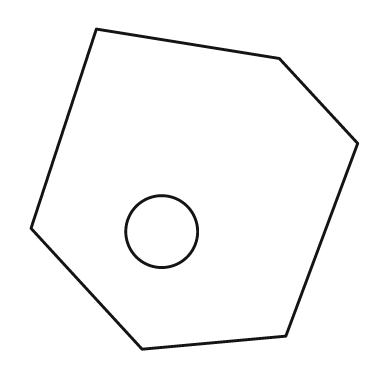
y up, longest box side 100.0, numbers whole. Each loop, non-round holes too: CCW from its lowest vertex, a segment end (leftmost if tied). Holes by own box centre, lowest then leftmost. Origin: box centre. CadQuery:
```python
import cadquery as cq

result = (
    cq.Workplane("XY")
    .moveTo(-16.0, -49.0)
    .lineTo(28.0, -45.0)
    .lineTo(50.0, 14.0)
    .lineTo(26.0, 40.0)
    .lineTo(-30.0, 49.0)
    .lineTo(-50.0, -12.0)
    .close()
    .moveTo(-10.0, -13.0)
    .circle(11.0)
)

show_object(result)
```